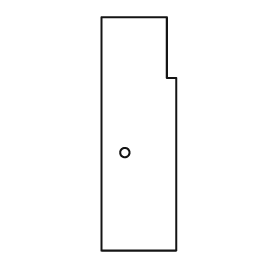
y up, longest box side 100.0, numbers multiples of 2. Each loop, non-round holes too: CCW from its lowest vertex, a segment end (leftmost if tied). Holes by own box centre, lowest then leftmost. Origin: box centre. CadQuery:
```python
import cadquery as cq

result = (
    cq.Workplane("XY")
    .moveTo(-16.0, -50.0)
    .lineTo(16.0, -50.0)
    .lineTo(16.0, 24.0)
    .lineTo(12.0, 24.0)
    .lineTo(12.0, 50.0)
    .lineTo(-16.0, 50.0)
    .close()
    .moveTo(-6.0, -8.0)
    .circle(2.0)
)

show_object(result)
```